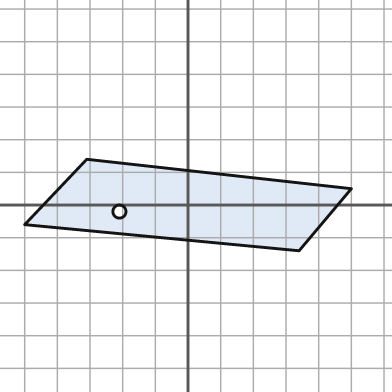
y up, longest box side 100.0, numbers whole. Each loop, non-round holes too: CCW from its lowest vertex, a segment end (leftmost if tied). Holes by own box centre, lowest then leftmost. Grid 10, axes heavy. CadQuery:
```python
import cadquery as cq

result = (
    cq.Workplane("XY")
    .moveTo(34.0, -14.0)
    .lineTo(50.0, 5.0)
    .lineTo(-31.0, 14.0)
    .lineTo(-50.0, -6.0)
    .close()
    .moveTo(-21.0, -2.0)
    .circle(2.0)
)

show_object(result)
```